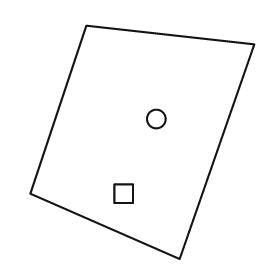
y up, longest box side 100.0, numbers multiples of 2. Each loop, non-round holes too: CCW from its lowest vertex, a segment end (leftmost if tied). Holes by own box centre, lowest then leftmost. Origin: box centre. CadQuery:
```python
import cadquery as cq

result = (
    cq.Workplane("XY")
    .moveTo(16.0, -50.0)
    .lineTo(48.0, 42.0)
    .lineTo(-24.0, 50.0)
    .lineTo(-48.0, -22.0)
    .close()
    .moveTo(-12.0, -26.0)
    .lineTo(-4.0, -26.0)
    .lineTo(-4.0, -18.0)
    .lineTo(-12.0, -18.0)
    .close()
    .moveTo(6.0, 10.0)
    .circle(4.0)
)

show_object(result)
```